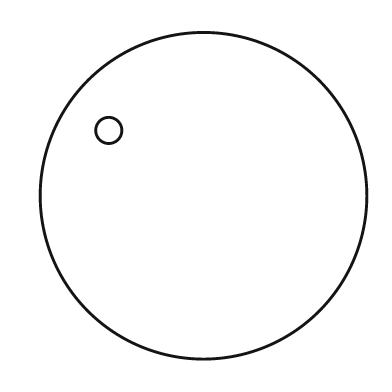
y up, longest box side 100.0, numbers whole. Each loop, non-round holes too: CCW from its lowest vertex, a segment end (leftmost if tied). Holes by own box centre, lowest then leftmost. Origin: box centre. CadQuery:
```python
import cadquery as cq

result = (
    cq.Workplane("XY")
    .moveTo(0.0, 0.0)
    .circle(50.0)
    .moveTo(-29.0, 20.0)
    .circle(4.0)
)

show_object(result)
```